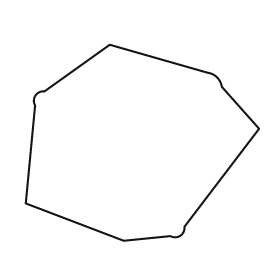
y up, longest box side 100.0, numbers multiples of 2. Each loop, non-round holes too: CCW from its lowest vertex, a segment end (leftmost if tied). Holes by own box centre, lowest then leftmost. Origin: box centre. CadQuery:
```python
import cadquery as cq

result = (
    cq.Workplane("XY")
    .moveTo(-8.0, -42.0)
    .lineTo(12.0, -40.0)
    .threePointArc((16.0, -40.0), (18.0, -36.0))
    .lineTo(50.0, 6.0)
    .lineTo(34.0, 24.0)
    .threePointArc((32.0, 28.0), (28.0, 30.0))
    .lineTo(-14.0, 42.0)
    .lineTo(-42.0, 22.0)
    .threePointArc((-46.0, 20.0), (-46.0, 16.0))
    .lineTo(-50.0, -26.0)
    .close()
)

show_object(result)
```